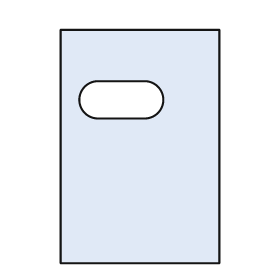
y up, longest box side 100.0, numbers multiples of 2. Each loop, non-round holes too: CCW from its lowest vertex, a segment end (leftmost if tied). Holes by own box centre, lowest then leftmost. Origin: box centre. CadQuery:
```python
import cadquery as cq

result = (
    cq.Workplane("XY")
    .moveTo(-34.0, -50.0)
    .lineTo(34.0, -50.0)
    .lineTo(34.0, 50.0)
    .lineTo(-34.0, 50.0)
    .close()
    .moveTo(-18.0, 12.0)
    .lineTo(2.0, 12.0)
    .threePointArc((10.0, 20.0), (2.0, 28.0))
    .lineTo(-18.0, 28.0)
    .threePointArc((-26.0, 20.0), (-18.0, 12.0))
    .close()
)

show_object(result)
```